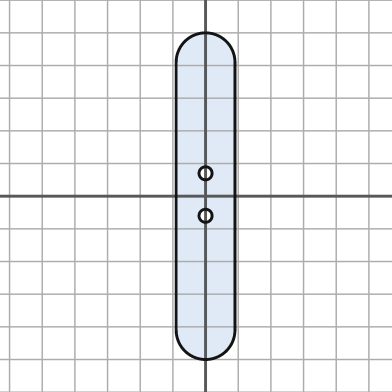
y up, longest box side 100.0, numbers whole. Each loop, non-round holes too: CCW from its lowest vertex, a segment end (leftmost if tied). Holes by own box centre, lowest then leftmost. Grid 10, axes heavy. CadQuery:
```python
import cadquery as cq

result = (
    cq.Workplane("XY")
    .moveTo(-9.0, -41.0)
    .threePointArc((0.0, -50.0), (9.0, -41.0))
    .lineTo(9.0, 41.0)
    .threePointArc((0.0, 50.0), (-9.0, 41.0))
    .close()
    .moveTo(0.0, -6.0)
    .circle(2.0)
    .moveTo(0.0, 7.0)
    .circle(2.0)
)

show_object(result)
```